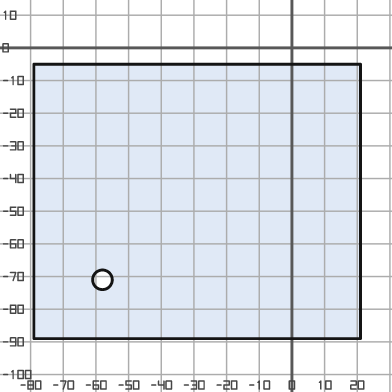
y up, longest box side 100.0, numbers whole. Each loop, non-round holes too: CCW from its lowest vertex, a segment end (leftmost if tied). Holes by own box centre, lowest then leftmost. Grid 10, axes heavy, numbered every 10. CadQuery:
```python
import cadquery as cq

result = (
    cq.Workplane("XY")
    .moveTo(-79.0, -89.0)
    .lineTo(21.0, -89.0)
    .lineTo(21.0, -5.0)
    .lineTo(-79.0, -5.0)
    .close()
    .moveTo(-58.0, -71.0)
    .circle(3.0)
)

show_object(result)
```